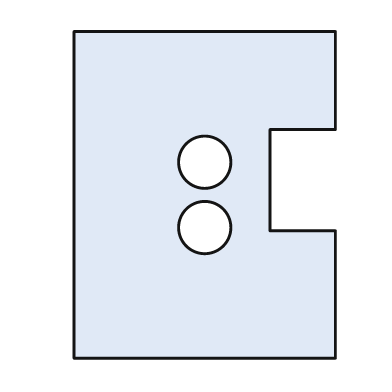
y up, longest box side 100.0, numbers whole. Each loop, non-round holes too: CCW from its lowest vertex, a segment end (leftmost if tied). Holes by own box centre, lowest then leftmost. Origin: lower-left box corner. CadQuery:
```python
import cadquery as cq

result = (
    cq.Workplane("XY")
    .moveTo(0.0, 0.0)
    .lineTo(80.0, 0.0)
    .lineTo(80.0, 39.0)
    .lineTo(60.0, 39.0)
    .lineTo(60.0, 70.0)
    .lineTo(80.0, 70.0)
    .lineTo(80.0, 100.0)
    .lineTo(0.0, 100.0)
    .close()
    .moveTo(40.0, 40.0)
    .circle(8.0)
    .moveTo(40.0, 60.0)
    .circle(8.0)
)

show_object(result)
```